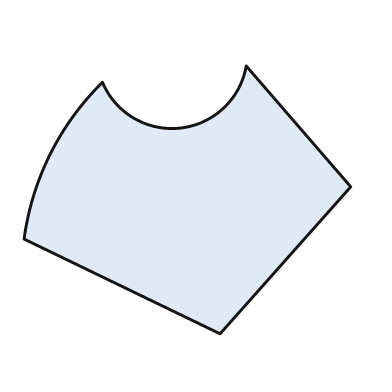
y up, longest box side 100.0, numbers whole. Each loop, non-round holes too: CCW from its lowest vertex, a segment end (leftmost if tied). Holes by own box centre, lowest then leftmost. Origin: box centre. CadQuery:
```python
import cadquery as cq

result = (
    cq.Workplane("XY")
    .moveTo(10.0, -41.0)
    .lineTo(50.0, 4.0)
    .lineTo(18.0, 41.0)
    .threePointArc((-2.0, 22.0), (-26.0, 36.0))
    .threePointArc((-42.0, 14.0), (-50.0, -12.0))
    .close()
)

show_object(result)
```